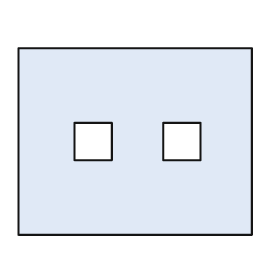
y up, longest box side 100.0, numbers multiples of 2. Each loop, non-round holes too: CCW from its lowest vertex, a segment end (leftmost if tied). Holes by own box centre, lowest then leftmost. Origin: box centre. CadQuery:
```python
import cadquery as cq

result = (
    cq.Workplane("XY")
    .moveTo(-50.0, -40.0)
    .lineTo(50.0, -40.0)
    .lineTo(50.0, 40.0)
    .lineTo(-50.0, 40.0)
    .close()
    .moveTo(-26.0, -8.0)
    .lineTo(-10.0, -8.0)
    .lineTo(-10.0, 8.0)
    .lineTo(-26.0, 8.0)
    .close()
    .moveTo(12.0, -8.0)
    .lineTo(28.0, -8.0)
    .lineTo(28.0, 8.0)
    .lineTo(12.0, 8.0)
    .close()
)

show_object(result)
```